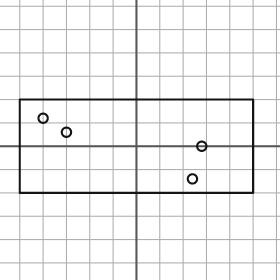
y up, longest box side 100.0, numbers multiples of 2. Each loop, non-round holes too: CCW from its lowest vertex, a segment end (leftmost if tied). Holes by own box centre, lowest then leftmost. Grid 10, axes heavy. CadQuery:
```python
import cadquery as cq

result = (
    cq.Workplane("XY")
    .moveTo(-50.0, -20.0)
    .lineTo(50.0, -20.0)
    .lineTo(50.0, 20.0)
    .lineTo(-50.0, 20.0)
    .close()
    .moveTo(24.0, -14.0)
    .circle(2.0)
    .moveTo(28.0, 0.0)
    .circle(2.0)
    .moveTo(-30.0, 6.0)
    .circle(2.0)
    .moveTo(-40.0, 12.0)
    .circle(2.0)
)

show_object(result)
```